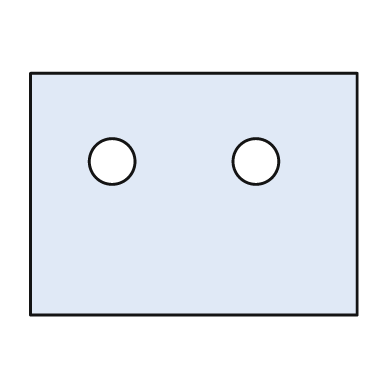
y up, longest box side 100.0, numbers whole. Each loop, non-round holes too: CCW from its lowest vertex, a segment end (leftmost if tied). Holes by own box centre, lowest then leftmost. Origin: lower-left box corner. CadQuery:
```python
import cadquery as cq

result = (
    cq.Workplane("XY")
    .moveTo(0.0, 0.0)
    .lineTo(100.0, 0.0)
    .lineTo(100.0, 74.0)
    .lineTo(0.0, 74.0)
    .close()
    .moveTo(25.0, 47.0)
    .circle(7.0)
    .moveTo(69.0, 47.0)
    .circle(7.0)
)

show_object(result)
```